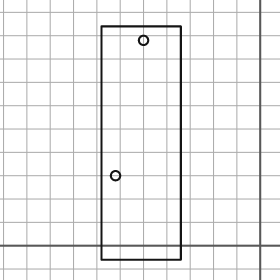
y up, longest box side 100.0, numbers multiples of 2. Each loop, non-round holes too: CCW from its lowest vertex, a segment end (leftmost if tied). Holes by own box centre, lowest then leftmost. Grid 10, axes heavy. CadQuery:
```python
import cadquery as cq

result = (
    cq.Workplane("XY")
    .moveTo(-68.0, -6.0)
    .lineTo(-34.0, -6.0)
    .lineTo(-34.0, 94.0)
    .lineTo(-68.0, 94.0)
    .close()
    .moveTo(-62.0, 30.0)
    .circle(2.0)
    .moveTo(-50.0, 88.0)
    .circle(2.0)
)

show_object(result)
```